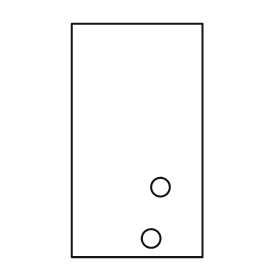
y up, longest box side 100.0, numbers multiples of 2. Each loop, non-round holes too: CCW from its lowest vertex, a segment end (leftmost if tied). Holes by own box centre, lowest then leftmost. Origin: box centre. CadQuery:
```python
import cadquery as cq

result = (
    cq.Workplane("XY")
    .moveTo(-28.0, -50.0)
    .lineTo(28.0, -50.0)
    .lineTo(28.0, 50.0)
    .lineTo(-28.0, 50.0)
    .close()
    .moveTo(6.0, -42.0)
    .circle(4.0)
    .moveTo(10.0, -20.0)
    .circle(4.0)
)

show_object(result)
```